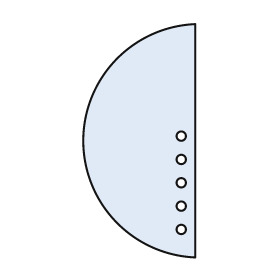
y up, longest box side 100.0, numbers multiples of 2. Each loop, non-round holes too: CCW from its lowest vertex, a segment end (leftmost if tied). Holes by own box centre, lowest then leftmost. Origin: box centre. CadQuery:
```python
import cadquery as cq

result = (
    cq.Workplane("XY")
    .moveTo(24.0, -50.0)
    .lineTo(24.0, 50.0)
    .threePointArc((-24.0, 0.0), (24.0, -50.0))
    .close()
    .moveTo(18.0, -38.0)
    .circle(2.0)
    .moveTo(18.0, -28.0)
    .circle(2.0)
    .moveTo(18.0, -18.0)
    .circle(2.0)
    .moveTo(18.0, -8.0)
    .circle(2.0)
    .moveTo(18.0, 2.0)
    .circle(2.0)
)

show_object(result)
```